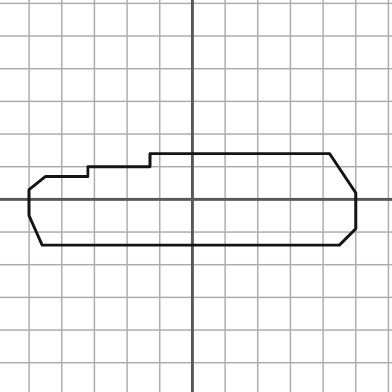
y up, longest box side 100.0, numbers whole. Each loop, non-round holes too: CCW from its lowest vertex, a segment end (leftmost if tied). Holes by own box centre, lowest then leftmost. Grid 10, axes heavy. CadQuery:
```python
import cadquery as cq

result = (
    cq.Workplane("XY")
    .moveTo(-46.0, -14.0)
    .lineTo(45.0, -14.0)
    .lineTo(50.0, -9.0)
    .lineTo(50.0, 2.0)
    .lineTo(42.0, 14.0)
    .lineTo(-13.0, 14.0)
    .lineTo(-13.0, 10.0)
    .lineTo(-32.0, 10.0)
    .lineTo(-32.0, 7.0)
    .lineTo(-45.0, 7.0)
    .lineTo(-50.0, 3.0)
    .lineTo(-50.0, -5.0)
    .close()
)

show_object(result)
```